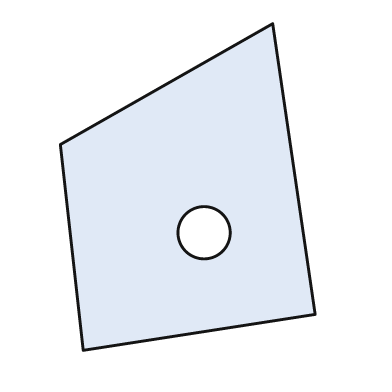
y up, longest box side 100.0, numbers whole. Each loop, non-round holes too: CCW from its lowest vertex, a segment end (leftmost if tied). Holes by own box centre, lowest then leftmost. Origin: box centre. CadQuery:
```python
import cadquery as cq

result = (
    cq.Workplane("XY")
    .moveTo(-32.0, -50.0)
    .lineTo(39.0, -39.0)
    .lineTo(26.0, 50.0)
    .lineTo(-39.0, 13.0)
    .close()
    .moveTo(5.0, -14.0)
    .circle(8.0)
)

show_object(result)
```